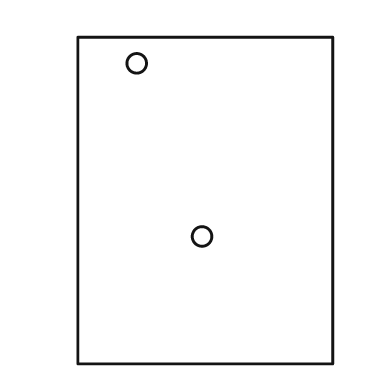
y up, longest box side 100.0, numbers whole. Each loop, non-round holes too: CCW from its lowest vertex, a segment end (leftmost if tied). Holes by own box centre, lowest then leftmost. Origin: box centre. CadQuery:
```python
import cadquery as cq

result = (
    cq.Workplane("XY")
    .moveTo(-39.0, -50.0)
    .lineTo(39.0, -50.0)
    .lineTo(39.0, 50.0)
    .lineTo(-39.0, 50.0)
    .close()
    .moveTo(-1.0, -11.0)
    .circle(3.0)
    .moveTo(-21.0, 42.0)
    .circle(3.0)
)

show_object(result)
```